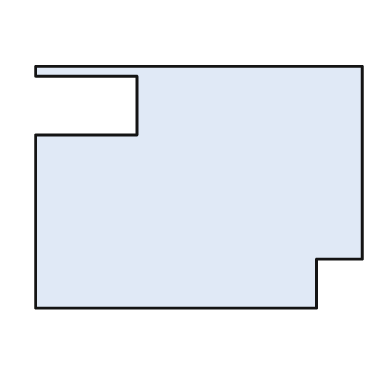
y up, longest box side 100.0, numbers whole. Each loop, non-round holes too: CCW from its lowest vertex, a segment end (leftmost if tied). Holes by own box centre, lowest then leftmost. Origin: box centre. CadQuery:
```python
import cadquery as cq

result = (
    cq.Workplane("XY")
    .moveTo(-50.0, -37.0)
    .lineTo(36.0, -37.0)
    .lineTo(36.0, -22.0)
    .lineTo(50.0, -22.0)
    .lineTo(50.0, 37.0)
    .lineTo(-50.0, 37.0)
    .lineTo(-50.0, 34.0)
    .lineTo(-19.0, 34.0)
    .lineTo(-19.0, 16.0)
    .lineTo(-50.0, 16.0)
    .close()
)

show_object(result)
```